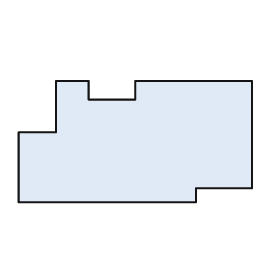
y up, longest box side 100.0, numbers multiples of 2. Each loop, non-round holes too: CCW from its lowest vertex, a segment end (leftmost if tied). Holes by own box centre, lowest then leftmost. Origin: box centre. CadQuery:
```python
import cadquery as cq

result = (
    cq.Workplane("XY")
    .moveTo(-50.0, -26.0)
    .lineTo(26.0, -26.0)
    .lineTo(26.0, -20.0)
    .lineTo(50.0, -20.0)
    .lineTo(50.0, 26.0)
    .lineTo(0.0, 26.0)
    .lineTo(0.0, 18.0)
    .lineTo(-20.0, 18.0)
    .lineTo(-20.0, 26.0)
    .lineTo(-34.0, 26.0)
    .lineTo(-34.0, 4.0)
    .lineTo(-50.0, 4.0)
    .close()
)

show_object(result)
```